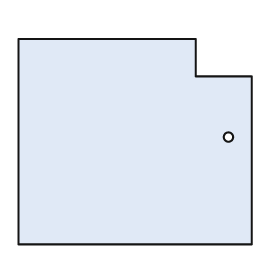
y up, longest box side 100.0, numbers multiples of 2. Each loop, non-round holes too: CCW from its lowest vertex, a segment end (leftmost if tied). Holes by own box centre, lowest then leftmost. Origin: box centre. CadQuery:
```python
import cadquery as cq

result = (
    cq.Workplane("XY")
    .moveTo(-50.0, -44.0)
    .lineTo(50.0, -44.0)
    .lineTo(50.0, 28.0)
    .lineTo(26.0, 28.0)
    .lineTo(26.0, 44.0)
    .lineTo(-50.0, 44.0)
    .close()
    .moveTo(40.0, 2.0)
    .circle(2.0)
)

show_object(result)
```